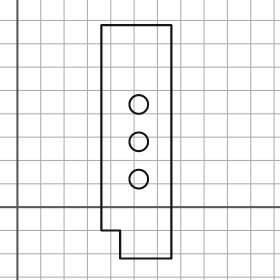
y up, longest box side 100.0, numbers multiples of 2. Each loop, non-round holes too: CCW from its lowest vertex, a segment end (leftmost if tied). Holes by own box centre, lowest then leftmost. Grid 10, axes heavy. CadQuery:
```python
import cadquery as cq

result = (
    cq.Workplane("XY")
    .moveTo(44.0, -22.0)
    .lineTo(66.0, -22.0)
    .lineTo(66.0, 78.0)
    .lineTo(36.0, 78.0)
    .lineTo(36.0, -10.0)
    .lineTo(44.0, -10.0)
    .close()
    .moveTo(52.0, 12.0)
    .circle(4.0)
    .moveTo(52.0, 28.0)
    .circle(4.0)
    .moveTo(52.0, 44.0)
    .circle(4.0)
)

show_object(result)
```